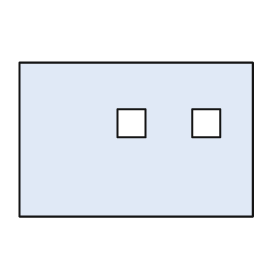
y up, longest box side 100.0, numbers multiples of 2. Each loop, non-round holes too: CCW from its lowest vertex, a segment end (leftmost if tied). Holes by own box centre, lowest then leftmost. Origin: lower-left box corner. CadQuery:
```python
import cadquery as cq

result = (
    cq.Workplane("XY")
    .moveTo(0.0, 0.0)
    .lineTo(100.0, 0.0)
    .lineTo(100.0, 66.0)
    .lineTo(0.0, 66.0)
    .close()
    .moveTo(42.0, 34.0)
    .lineTo(54.0, 34.0)
    .lineTo(54.0, 46.0)
    .lineTo(42.0, 46.0)
    .close()
    .moveTo(74.0, 34.0)
    .lineTo(86.0, 34.0)
    .lineTo(86.0, 46.0)
    .lineTo(74.0, 46.0)
    .close()
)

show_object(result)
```